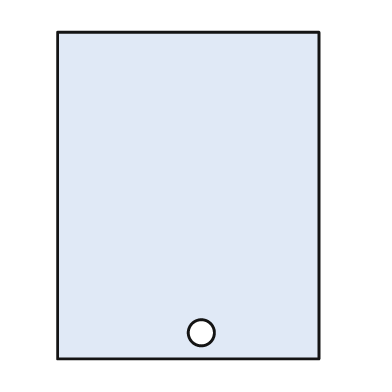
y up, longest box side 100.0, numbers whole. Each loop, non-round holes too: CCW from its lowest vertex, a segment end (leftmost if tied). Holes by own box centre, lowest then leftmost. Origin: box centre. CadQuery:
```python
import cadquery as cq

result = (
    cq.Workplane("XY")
    .moveTo(-40.0, -50.0)
    .lineTo(40.0, -50.0)
    .lineTo(40.0, 50.0)
    .lineTo(-40.0, 50.0)
    .close()
    .moveTo(4.0, -42.0)
    .circle(4.0)
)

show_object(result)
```